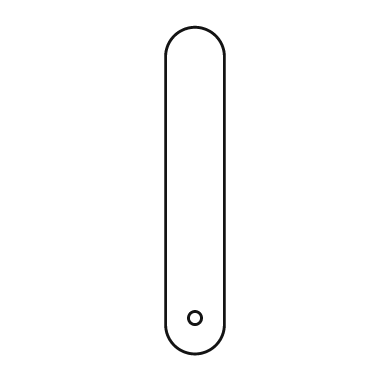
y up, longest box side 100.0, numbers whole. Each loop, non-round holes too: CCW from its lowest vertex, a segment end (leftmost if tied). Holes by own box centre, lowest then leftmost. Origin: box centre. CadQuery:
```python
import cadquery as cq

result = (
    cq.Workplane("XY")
    .moveTo(-9.0, -41.0)
    .threePointArc((0.0, -50.0), (9.0, -41.0))
    .lineTo(9.0, 41.0)
    .threePointArc((0.0, 50.0), (-9.0, 41.0))
    .close()
    .moveTo(0.0, -39.0)
    .circle(2.0)
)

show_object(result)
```